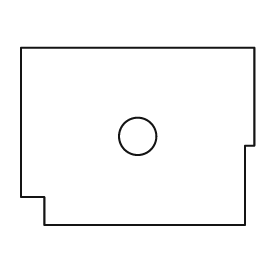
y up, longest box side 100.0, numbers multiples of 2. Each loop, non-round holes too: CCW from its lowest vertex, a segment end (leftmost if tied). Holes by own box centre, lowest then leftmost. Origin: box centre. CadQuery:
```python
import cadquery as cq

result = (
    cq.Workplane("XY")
    .moveTo(-40.0, -38.0)
    .lineTo(46.0, -38.0)
    .lineTo(46.0, -4.0)
    .lineTo(50.0, -4.0)
    .lineTo(50.0, 38.0)
    .lineTo(-50.0, 38.0)
    .lineTo(-50.0, -26.0)
    .lineTo(-40.0, -26.0)
    .close()
    .moveTo(0.0, 0.0)
    .circle(8.0)
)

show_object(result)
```